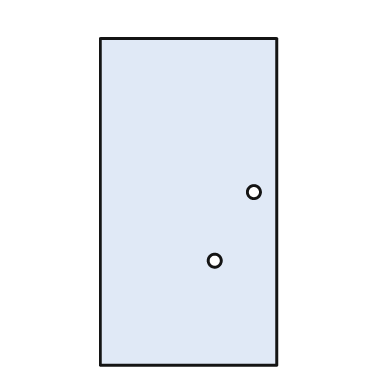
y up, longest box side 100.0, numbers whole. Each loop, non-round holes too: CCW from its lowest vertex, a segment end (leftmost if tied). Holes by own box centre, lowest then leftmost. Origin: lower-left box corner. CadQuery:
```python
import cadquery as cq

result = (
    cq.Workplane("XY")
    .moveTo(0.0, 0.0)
    .lineTo(54.0, 0.0)
    .lineTo(54.0, 100.0)
    .lineTo(0.0, 100.0)
    .close()
    .moveTo(35.0, 32.0)
    .circle(2.0)
    .moveTo(47.0, 53.0)
    .circle(2.0)
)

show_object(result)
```